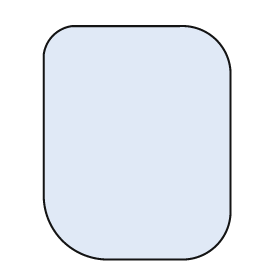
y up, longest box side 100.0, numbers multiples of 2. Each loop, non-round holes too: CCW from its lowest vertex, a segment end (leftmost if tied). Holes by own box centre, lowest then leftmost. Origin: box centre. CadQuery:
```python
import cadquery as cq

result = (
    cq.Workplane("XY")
    .moveTo(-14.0, -50.0)
    .lineTo(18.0, -50.0)
    .threePointArc((34.0, -44.0), (40.0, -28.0))
    .lineTo(40.0, 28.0)
    .threePointArc((34.0, 44.0), (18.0, 50.0))
    .lineTo(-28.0, 50.0)
    .threePointArc((-36.0, 46.0), (-40.0, 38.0))
    .lineTo(-40.0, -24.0)
    .threePointArc((-32.0, -42.0), (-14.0, -50.0))
    .close()
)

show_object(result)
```